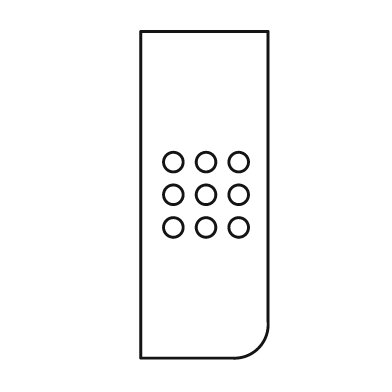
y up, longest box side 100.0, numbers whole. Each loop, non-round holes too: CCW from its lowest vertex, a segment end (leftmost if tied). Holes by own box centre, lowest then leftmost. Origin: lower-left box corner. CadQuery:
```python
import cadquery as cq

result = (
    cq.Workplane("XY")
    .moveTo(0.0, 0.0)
    .lineTo(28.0, 0.0)
    .threePointArc((36.0, 3.0), (39.0, 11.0))
    .lineTo(39.0, 100.0)
    .lineTo(0.0, 100.0)
    .close()
    .moveTo(10.0, 40.0)
    .circle(3.0)
    .moveTo(20.0, 40.0)
    .circle(3.0)
    .moveTo(30.0, 40.0)
    .circle(3.0)
    .moveTo(10.0, 50.0)
    .circle(3.0)
    .moveTo(20.0, 50.0)
    .circle(3.0)
    .moveTo(30.0, 50.0)
    .circle(3.0)
    .moveTo(10.0, 60.0)
    .circle(3.0)
    .moveTo(20.0, 60.0)
    .circle(3.0)
    .moveTo(30.0, 60.0)
    .circle(3.0)
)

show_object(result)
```